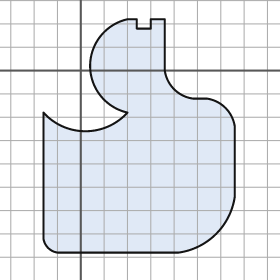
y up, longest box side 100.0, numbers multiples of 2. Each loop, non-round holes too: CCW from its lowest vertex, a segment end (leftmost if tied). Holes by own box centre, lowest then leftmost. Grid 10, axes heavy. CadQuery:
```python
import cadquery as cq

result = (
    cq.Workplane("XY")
    .moveTo(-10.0, -78.0)
    .lineTo(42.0, -78.0)
    .threePointArc((58.0, -70.0), (66.0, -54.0))
    .lineTo(66.0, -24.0)
    .threePointArc((62.0, -16.0), (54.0, -12.0))
    .lineTo(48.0, -12.0)
    .threePointArc((40.0, -8.0), (36.0, 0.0))
    .lineTo(36.0, 22.0)
    .lineTo(30.0, 22.0)
    .lineTo(30.0, 18.0)
    .lineTo(24.0, 18.0)
    .lineTo(24.0, 22.0)
    .lineTo(20.0, 22.0)
    .threePointArc((4.0, 2.0), (20.0, -18.0))
    .threePointArc((2.0, -26.0), (-16.0, -18.0))
    .lineTo(-16.0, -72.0)
    .threePointArc((-14.0, -76.0), (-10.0, -78.0))
    .close()
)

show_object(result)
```